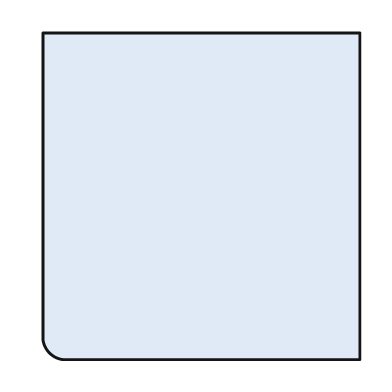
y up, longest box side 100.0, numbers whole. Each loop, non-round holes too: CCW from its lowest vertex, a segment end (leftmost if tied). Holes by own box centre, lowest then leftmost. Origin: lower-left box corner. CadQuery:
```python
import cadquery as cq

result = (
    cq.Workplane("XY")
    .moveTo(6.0, 0.0)
    .lineTo(97.0, 0.0)
    .lineTo(97.0, 100.0)
    .lineTo(0.0, 100.0)
    .lineTo(0.0, 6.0)
    .threePointArc((2.0, 2.0), (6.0, 0.0))
    .close()
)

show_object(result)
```